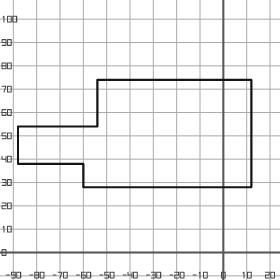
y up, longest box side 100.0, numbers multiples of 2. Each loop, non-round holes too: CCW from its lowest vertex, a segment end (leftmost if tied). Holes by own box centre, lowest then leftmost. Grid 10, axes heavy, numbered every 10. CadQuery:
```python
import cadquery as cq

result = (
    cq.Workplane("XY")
    .moveTo(-60.0, 28.0)
    .lineTo(12.0, 28.0)
    .lineTo(12.0, 74.0)
    .lineTo(-54.0, 74.0)
    .lineTo(-54.0, 54.0)
    .lineTo(-88.0, 54.0)
    .lineTo(-88.0, 38.0)
    .lineTo(-60.0, 38.0)
    .close()
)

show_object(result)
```